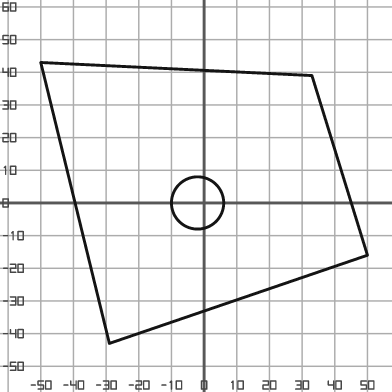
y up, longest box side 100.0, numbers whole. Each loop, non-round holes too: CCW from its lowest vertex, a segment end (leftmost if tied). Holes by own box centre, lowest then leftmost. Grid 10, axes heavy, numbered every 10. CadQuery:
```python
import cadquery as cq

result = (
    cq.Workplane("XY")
    .moveTo(-29.0, -43.0)
    .lineTo(50.0, -16.0)
    .lineTo(33.0, 39.0)
    .lineTo(-50.0, 43.0)
    .close()
    .moveTo(-2.0, 0.0)
    .circle(8.0)
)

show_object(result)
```